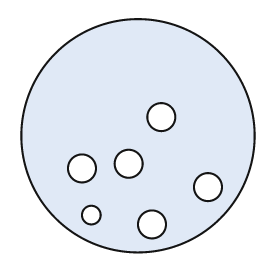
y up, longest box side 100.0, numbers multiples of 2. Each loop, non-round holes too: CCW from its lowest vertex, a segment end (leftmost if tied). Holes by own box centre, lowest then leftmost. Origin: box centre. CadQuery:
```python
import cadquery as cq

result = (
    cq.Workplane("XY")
    .moveTo(0.0, 0.0)
    .circle(50.0)
    .moveTo(6.0, -38.0)
    .circle(6.0)
    .moveTo(-20.0, -34.0)
    .circle(4.0)
    .moveTo(30.0, -22.0)
    .circle(6.0)
    .moveTo(-24.0, -14.0)
    .circle(6.0)
    .moveTo(-4.0, -12.0)
    .circle(6.0)
    .moveTo(10.0, 8.0)
    .circle(6.0)
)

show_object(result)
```